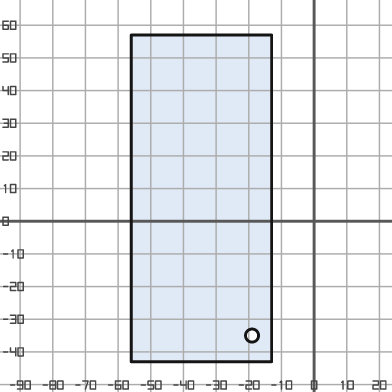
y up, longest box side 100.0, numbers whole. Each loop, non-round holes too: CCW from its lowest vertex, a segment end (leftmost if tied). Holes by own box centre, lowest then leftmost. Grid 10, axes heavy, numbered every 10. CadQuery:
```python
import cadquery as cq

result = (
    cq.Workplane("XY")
    .moveTo(-56.0, -43.0)
    .lineTo(-13.0, -43.0)
    .lineTo(-13.0, 57.0)
    .lineTo(-56.0, 57.0)
    .close()
    .moveTo(-19.0, -35.0)
    .circle(2.0)
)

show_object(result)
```